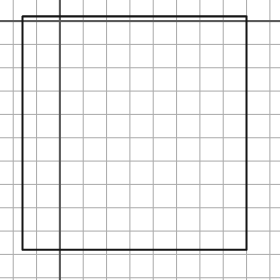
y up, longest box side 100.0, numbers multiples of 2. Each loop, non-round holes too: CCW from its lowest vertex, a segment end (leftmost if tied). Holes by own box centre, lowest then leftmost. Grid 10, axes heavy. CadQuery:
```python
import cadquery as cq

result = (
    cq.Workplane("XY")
    .moveTo(-16.0, -98.0)
    .lineTo(80.0, -98.0)
    .lineTo(80.0, 2.0)
    .lineTo(-16.0, 2.0)
    .close()
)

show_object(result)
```